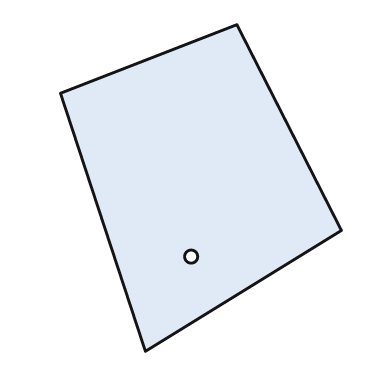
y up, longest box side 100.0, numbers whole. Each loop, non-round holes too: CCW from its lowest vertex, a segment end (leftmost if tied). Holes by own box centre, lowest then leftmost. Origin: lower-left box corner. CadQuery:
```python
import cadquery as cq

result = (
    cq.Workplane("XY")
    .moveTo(26.0, 0.0)
    .lineTo(86.0, 37.0)
    .lineTo(54.0, 100.0)
    .lineTo(0.0, 79.0)
    .close()
    .moveTo(40.0, 29.0)
    .circle(2.0)
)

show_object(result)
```